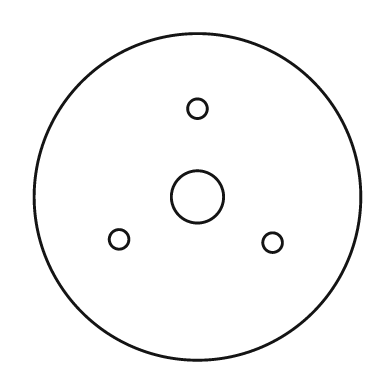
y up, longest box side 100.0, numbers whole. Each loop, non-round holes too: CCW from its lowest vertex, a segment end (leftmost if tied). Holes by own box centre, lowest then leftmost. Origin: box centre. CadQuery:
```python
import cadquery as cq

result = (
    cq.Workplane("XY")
    .moveTo(0.0, 0.0)
    .circle(50.0)
    .moveTo(23.0, -14.0)
    .circle(3.0)
    .moveTo(-24.0, -13.0)
    .circle(3.0)
    .moveTo(0.0, 0.0)
    .circle(8.0)
    .moveTo(0.0, 27.0)
    .circle(3.0)
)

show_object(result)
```